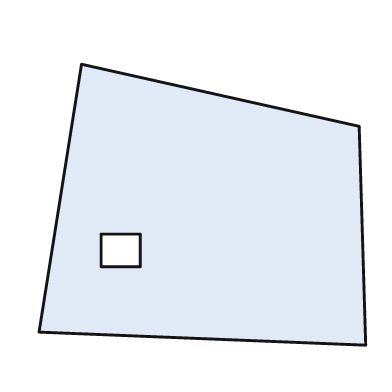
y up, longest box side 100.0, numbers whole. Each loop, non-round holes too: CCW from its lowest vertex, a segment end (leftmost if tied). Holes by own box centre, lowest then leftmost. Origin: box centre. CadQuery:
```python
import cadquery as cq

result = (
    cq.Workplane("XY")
    .moveTo(50.0, -43.0)
    .lineTo(48.0, 24.0)
    .lineTo(-37.0, 43.0)
    .lineTo(-50.0, -39.0)
    .close()
    .moveTo(-31.0, -19.0)
    .lineTo(-19.0, -19.0)
    .lineTo(-19.0, -9.0)
    .lineTo(-31.0, -9.0)
    .close()
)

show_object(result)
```